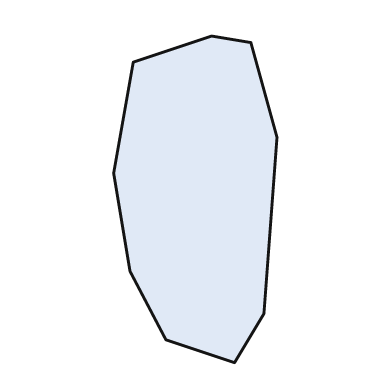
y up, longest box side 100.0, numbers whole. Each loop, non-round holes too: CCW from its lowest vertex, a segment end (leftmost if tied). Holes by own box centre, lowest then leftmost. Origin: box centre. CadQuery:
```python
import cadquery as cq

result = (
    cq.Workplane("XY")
    .moveTo(12.0, -50.0)
    .lineTo(21.0, -35.0)
    .lineTo(25.0, 19.0)
    .lineTo(17.0, 48.0)
    .lineTo(5.0, 50.0)
    .lineTo(-19.0, 42.0)
    .lineTo(-25.0, 8.0)
    .lineTo(-20.0, -22.0)
    .lineTo(-9.0, -43.0)
    .close()
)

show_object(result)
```